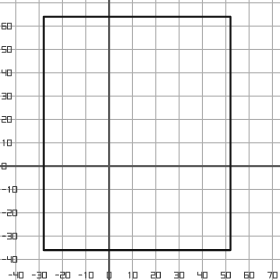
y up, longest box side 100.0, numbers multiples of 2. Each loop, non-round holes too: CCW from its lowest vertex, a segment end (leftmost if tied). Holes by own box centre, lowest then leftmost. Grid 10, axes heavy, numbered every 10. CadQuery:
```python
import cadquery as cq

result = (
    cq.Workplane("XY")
    .moveTo(-28.0, -36.0)
    .lineTo(52.0, -36.0)
    .lineTo(52.0, 64.0)
    .lineTo(-28.0, 64.0)
    .close()
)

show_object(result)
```